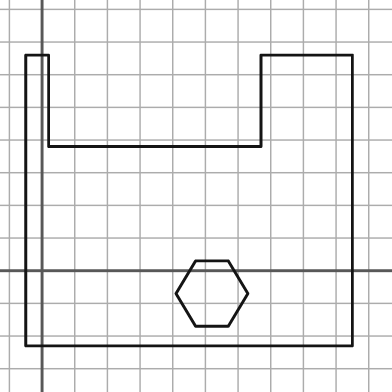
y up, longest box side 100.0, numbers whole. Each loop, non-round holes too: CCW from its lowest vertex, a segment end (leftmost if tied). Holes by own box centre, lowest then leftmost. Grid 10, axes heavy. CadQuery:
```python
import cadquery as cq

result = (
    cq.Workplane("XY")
    .moveTo(-5.0, -23.0)
    .lineTo(95.0, -23.0)
    .lineTo(95.0, 66.0)
    .lineTo(67.0, 66.0)
    .lineTo(67.0, 38.0)
    .lineTo(2.0, 38.0)
    .lineTo(2.0, 66.0)
    .lineTo(-5.0, 66.0)
    .close()
    .moveTo(47.0, -17.0)
    .lineTo(57.0, -17.0)
    .lineTo(63.0, -7.0)
    .lineTo(57.0, 3.0)
    .lineTo(47.0, 3.0)
    .lineTo(41.0, -7.0)
    .close()
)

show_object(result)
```